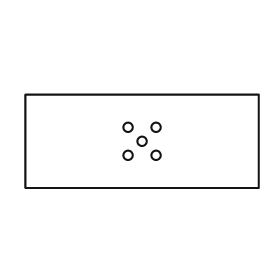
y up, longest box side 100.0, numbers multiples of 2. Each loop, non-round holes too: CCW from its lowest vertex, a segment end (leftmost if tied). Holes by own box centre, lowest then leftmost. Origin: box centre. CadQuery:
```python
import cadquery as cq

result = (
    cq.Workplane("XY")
    .moveTo(-50.0, -20.0)
    .lineTo(50.0, -20.0)
    .lineTo(50.0, 20.0)
    .lineTo(-50.0, 20.0)
    .close()
    .moveTo(-6.0, -6.0)
    .circle(2.0)
    .moveTo(6.0, -6.0)
    .circle(2.0)
    .moveTo(0.0, 0.0)
    .circle(2.0)
    .moveTo(-6.0, 6.0)
    .circle(2.0)
    .moveTo(6.0, 6.0)
    .circle(2.0)
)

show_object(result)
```